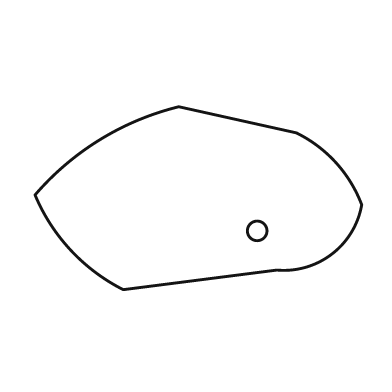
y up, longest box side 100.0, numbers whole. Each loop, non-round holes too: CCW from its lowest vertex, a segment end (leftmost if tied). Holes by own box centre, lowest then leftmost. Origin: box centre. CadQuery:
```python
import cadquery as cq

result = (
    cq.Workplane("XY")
    .moveTo(-23.0, -28.0)
    .lineTo(24.0, -22.0)
    .threePointArc((41.0, -17.0), (50.0, -2.0))
    .threePointArc((42.0, 11.0), (30.0, 20.0))
    .lineTo(-6.0, 28.0)
    .threePointArc((-30.0, 18.0), (-50.0, 1.0))
    .threePointArc((-39.0, -16.0), (-23.0, -28.0))
    .close()
    .moveTo(18.0, -10.0)
    .circle(3.0)
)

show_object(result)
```